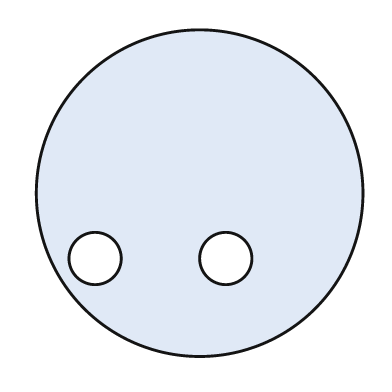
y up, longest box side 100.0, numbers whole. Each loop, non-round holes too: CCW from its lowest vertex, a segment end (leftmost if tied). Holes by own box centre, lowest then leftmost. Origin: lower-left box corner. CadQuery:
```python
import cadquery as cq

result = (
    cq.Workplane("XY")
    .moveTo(50.0, 50.0)
    .circle(50.0)
    .moveTo(18.0, 30.0)
    .circle(8.0)
    .moveTo(58.0, 30.0)
    .circle(8.0)
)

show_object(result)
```